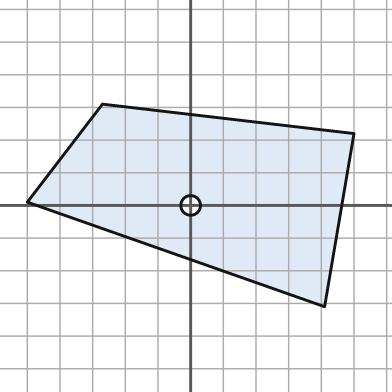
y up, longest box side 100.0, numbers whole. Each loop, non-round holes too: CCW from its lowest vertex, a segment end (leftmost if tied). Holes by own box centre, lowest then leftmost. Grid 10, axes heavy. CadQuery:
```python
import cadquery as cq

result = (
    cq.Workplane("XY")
    .moveTo(41.0, -31.0)
    .lineTo(50.0, 22.0)
    .lineTo(-27.0, 31.0)
    .lineTo(-50.0, 1.0)
    .close()
    .moveTo(0.0, 0.0)
    .circle(3.0)
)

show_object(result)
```